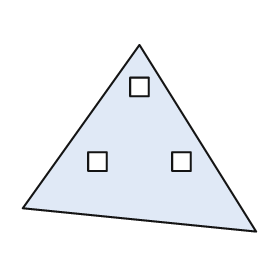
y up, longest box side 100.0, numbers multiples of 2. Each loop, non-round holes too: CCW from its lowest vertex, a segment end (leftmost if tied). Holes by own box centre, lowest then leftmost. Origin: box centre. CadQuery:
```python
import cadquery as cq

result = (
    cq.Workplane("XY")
    .moveTo(50.0, -40.0)
    .lineTo(0.0, 40.0)
    .lineTo(-50.0, -30.0)
    .close()
    .moveTo(-22.0, -14.0)
    .lineTo(-14.0, -14.0)
    .lineTo(-14.0, -6.0)
    .lineTo(-22.0, -6.0)
    .close()
    .moveTo(14.0, -14.0)
    .lineTo(22.0, -14.0)
    .lineTo(22.0, -6.0)
    .lineTo(14.0, -6.0)
    .close()
    .moveTo(-4.0, 18.0)
    .lineTo(4.0, 18.0)
    .lineTo(4.0, 26.0)
    .lineTo(-4.0, 26.0)
    .close()
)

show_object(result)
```